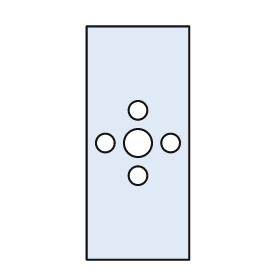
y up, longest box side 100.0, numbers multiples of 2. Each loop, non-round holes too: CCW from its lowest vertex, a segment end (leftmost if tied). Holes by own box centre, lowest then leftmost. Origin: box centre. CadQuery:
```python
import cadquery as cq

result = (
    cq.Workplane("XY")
    .moveTo(-22.0, -50.0)
    .lineTo(22.0, -50.0)
    .lineTo(22.0, 50.0)
    .lineTo(-22.0, 50.0)
    .close()
    .moveTo(0.0, -14.0)
    .circle(4.0)
    .moveTo(-14.0, 0.0)
    .circle(4.0)
    .moveTo(0.0, 0.0)
    .circle(6.0)
    .moveTo(14.0, 0.0)
    .circle(4.0)
    .moveTo(0.0, 14.0)
    .circle(4.0)
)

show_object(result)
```